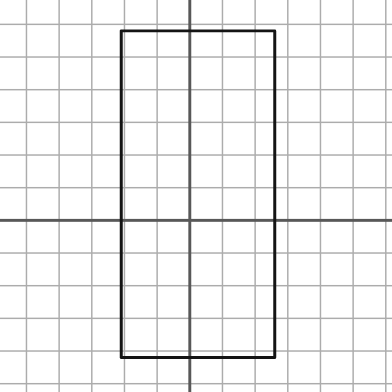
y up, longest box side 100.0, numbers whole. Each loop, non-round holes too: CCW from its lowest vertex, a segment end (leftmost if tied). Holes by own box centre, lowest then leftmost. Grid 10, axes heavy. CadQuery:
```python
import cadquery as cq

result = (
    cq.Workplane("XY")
    .moveTo(-21.0, -42.0)
    .lineTo(26.0, -42.0)
    .lineTo(26.0, 58.0)
    .lineTo(-21.0, 58.0)
    .close()
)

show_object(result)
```